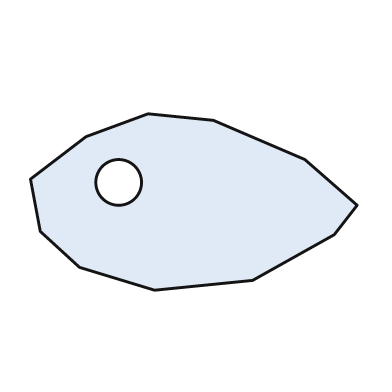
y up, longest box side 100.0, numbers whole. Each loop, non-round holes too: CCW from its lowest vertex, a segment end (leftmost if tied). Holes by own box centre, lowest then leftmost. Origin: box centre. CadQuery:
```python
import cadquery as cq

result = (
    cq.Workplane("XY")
    .moveTo(-12.0, -27.0)
    .lineTo(18.0, -24.0)
    .lineTo(43.0, -10.0)
    .lineTo(50.0, -1.0)
    .lineTo(34.0, 13.0)
    .lineTo(6.0, 25.0)
    .lineTo(-14.0, 27.0)
    .lineTo(-33.0, 20.0)
    .lineTo(-50.0, 7.0)
    .lineTo(-47.0, -9.0)
    .lineTo(-35.0, -20.0)
    .close()
    .moveTo(-23.0, 6.0)
    .circle(7.0)
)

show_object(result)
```